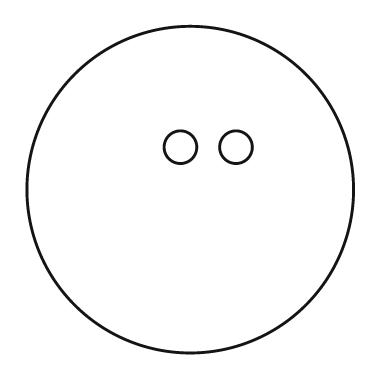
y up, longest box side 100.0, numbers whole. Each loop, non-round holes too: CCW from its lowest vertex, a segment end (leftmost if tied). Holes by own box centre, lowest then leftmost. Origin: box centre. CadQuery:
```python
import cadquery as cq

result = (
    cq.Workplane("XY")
    .moveTo(0.0, 0.0)
    .circle(50.0)
    .moveTo(-3.0, 13.0)
    .circle(5.0)
    .moveTo(14.0, 13.0)
    .circle(5.0)
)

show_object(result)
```